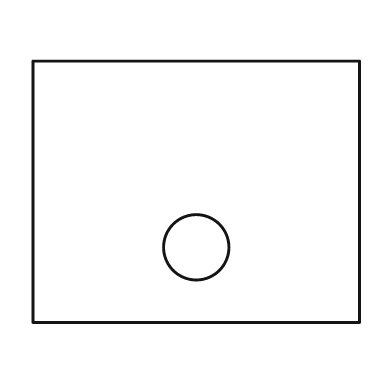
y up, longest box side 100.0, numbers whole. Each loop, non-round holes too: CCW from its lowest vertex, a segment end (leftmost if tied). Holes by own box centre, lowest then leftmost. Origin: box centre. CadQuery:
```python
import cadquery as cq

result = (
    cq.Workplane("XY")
    .moveTo(-50.0, -40.0)
    .lineTo(50.0, -40.0)
    .lineTo(50.0, 40.0)
    .lineTo(-50.0, 40.0)
    .close()
    .moveTo(0.0, -17.0)
    .circle(10.0)
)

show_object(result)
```